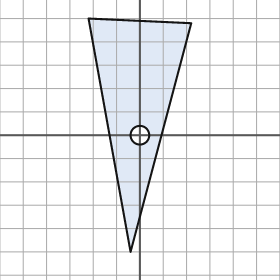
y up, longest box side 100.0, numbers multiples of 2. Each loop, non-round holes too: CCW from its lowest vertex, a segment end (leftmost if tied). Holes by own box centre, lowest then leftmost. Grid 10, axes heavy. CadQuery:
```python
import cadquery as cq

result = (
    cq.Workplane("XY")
    .moveTo(-4.0, -50.0)
    .lineTo(22.0, 48.0)
    .lineTo(-22.0, 50.0)
    .close()
    .moveTo(0.0, 0.0)
    .circle(4.0)
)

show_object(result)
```